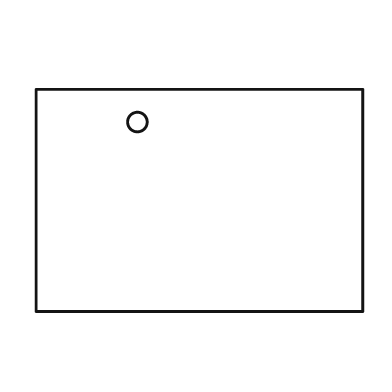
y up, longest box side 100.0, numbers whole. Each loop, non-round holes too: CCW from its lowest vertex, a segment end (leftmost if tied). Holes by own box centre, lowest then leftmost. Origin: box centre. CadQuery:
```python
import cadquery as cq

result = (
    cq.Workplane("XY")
    .moveTo(-50.0, -34.0)
    .lineTo(50.0, -34.0)
    .lineTo(50.0, 34.0)
    .lineTo(-50.0, 34.0)
    .close()
    .moveTo(-19.0, 24.0)
    .circle(3.0)
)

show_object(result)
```